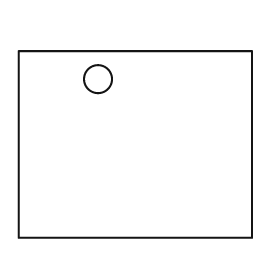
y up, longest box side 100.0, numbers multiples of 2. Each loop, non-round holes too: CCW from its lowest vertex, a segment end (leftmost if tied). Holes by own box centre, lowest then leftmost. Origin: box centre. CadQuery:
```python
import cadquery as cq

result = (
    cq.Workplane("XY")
    .moveTo(-50.0, -40.0)
    .lineTo(50.0, -40.0)
    .lineTo(50.0, 40.0)
    .lineTo(-50.0, 40.0)
    .close()
    .moveTo(-16.0, 28.0)
    .circle(6.0)
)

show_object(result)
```